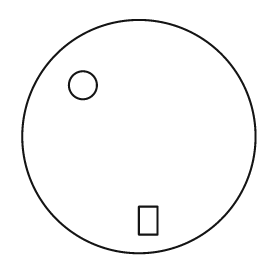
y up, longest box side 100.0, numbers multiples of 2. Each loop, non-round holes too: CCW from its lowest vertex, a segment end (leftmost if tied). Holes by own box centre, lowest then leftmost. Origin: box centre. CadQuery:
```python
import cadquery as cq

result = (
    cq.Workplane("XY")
    .moveTo(0.0, 0.0)
    .circle(50.0)
    .moveTo(0.0, -42.0)
    .lineTo(8.0, -42.0)
    .lineTo(8.0, -30.0)
    .lineTo(0.0, -30.0)
    .close()
    .moveTo(-24.0, 22.0)
    .circle(6.0)
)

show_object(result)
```